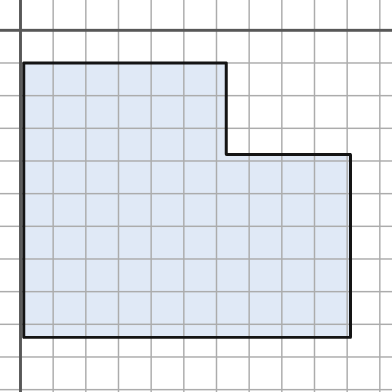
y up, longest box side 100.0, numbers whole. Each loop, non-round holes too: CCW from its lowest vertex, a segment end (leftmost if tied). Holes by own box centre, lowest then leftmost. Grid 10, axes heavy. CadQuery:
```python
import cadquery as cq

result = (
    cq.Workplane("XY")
    .moveTo(1.0, -94.0)
    .lineTo(101.0, -94.0)
    .lineTo(101.0, -38.0)
    .lineTo(63.0, -38.0)
    .lineTo(63.0, -10.0)
    .lineTo(1.0, -10.0)
    .close()
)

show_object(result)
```